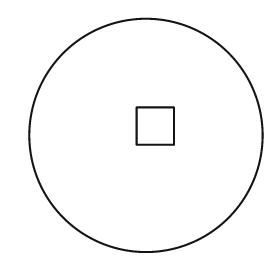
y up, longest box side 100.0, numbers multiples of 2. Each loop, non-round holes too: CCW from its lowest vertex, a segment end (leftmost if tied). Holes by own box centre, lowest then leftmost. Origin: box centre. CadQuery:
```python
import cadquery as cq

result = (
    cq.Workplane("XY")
    .moveTo(0.0, 0.0)
    .circle(50.0)
    .moveTo(-4.0, -4.0)
    .lineTo(12.0, -4.0)
    .lineTo(12.0, 12.0)
    .lineTo(-4.0, 12.0)
    .close()
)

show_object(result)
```